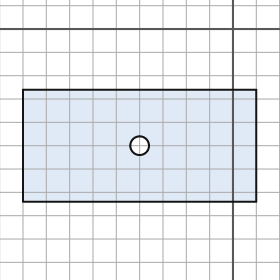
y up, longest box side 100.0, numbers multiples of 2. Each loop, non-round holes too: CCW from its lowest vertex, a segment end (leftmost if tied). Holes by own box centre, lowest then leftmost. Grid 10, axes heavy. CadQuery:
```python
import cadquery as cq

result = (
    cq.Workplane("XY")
    .moveTo(-90.0, -74.0)
    .lineTo(10.0, -74.0)
    .lineTo(10.0, -26.0)
    .lineTo(-90.0, -26.0)
    .close()
    .moveTo(-40.0, -50.0)
    .circle(4.0)
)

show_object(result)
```